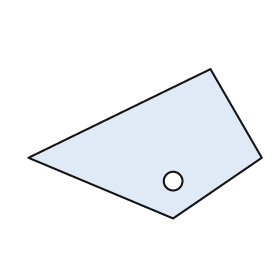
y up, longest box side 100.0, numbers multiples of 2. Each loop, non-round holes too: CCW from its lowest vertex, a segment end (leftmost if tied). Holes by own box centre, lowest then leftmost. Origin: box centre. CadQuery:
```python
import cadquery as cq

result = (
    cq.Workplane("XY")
    .moveTo(12.0, -32.0)
    .lineTo(50.0, -6.0)
    .lineTo(28.0, 32.0)
    .lineTo(-50.0, -6.0)
    .close()
    .moveTo(12.0, -16.0)
    .circle(4.0)
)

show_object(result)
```